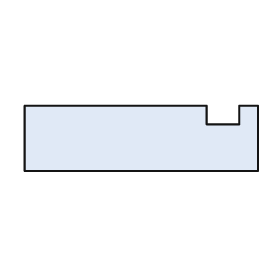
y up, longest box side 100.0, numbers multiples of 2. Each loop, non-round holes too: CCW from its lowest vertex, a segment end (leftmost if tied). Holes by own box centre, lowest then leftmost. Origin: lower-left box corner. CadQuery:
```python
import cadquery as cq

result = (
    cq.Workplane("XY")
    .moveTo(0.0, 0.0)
    .lineTo(100.0, 0.0)
    .lineTo(100.0, 28.0)
    .lineTo(92.0, 28.0)
    .lineTo(92.0, 20.0)
    .lineTo(78.0, 20.0)
    .lineTo(78.0, 28.0)
    .lineTo(0.0, 28.0)
    .close()
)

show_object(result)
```